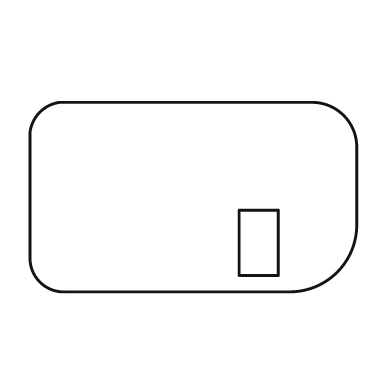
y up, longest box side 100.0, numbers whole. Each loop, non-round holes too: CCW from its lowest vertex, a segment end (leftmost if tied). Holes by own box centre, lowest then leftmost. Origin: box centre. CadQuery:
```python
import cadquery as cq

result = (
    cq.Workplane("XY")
    .moveTo(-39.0, -29.0)
    .lineTo(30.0, -29.0)
    .threePointArc((44.0, -23.0), (50.0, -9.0))
    .lineTo(50.0, 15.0)
    .threePointArc((46.0, 25.0), (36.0, 29.0))
    .lineTo(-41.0, 29.0)
    .threePointArc((-47.0, 26.0), (-50.0, 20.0))
    .lineTo(-50.0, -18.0)
    .threePointArc((-47.0, -26.0), (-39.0, -29.0))
    .close()
    .moveTo(14.0, -24.0)
    .lineTo(26.0, -24.0)
    .lineTo(26.0, -4.0)
    .lineTo(14.0, -4.0)
    .close()
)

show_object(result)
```